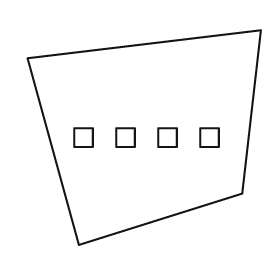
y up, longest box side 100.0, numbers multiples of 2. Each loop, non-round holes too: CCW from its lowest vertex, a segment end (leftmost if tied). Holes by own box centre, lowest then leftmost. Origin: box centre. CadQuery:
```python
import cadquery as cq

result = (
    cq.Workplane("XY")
    .moveTo(-28.0, -46.0)
    .lineTo(42.0, -24.0)
    .lineTo(50.0, 46.0)
    .lineTo(-50.0, 34.0)
    .close()
    .moveTo(-30.0, -4.0)
    .lineTo(-22.0, -4.0)
    .lineTo(-22.0, 4.0)
    .lineTo(-30.0, 4.0)
    .close()
    .moveTo(-12.0, -4.0)
    .lineTo(-4.0, -4.0)
    .lineTo(-4.0, 4.0)
    .lineTo(-12.0, 4.0)
    .close()
    .moveTo(6.0, -4.0)
    .lineTo(14.0, -4.0)
    .lineTo(14.0, 4.0)
    .lineTo(6.0, 4.0)
    .close()
    .moveTo(24.0, -4.0)
    .lineTo(32.0, -4.0)
    .lineTo(32.0, 4.0)
    .lineTo(24.0, 4.0)
    .close()
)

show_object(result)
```